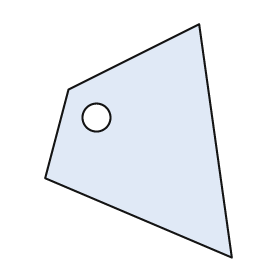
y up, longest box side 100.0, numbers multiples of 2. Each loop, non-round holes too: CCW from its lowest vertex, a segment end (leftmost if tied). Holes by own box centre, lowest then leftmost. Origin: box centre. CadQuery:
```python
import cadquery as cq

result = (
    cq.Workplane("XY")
    .moveTo(40.0, -50.0)
    .lineTo(26.0, 50.0)
    .lineTo(-30.0, 22.0)
    .lineTo(-40.0, -16.0)
    .close()
    .moveTo(-18.0, 10.0)
    .circle(6.0)
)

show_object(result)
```